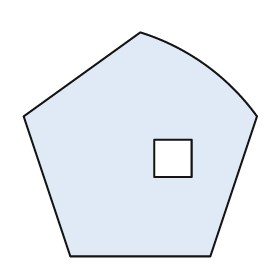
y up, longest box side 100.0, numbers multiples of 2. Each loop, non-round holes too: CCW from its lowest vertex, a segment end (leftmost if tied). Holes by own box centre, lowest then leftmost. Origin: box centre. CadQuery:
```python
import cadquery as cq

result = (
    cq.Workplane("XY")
    .moveTo(-30.0, -48.0)
    .lineTo(30.0, -48.0)
    .lineTo(50.0, 12.0)
    .threePointArc((28.0, 34.0), (0.0, 48.0))
    .lineTo(-50.0, 12.0)
    .close()
    .moveTo(6.0, -14.0)
    .lineTo(22.0, -14.0)
    .lineTo(22.0, 2.0)
    .lineTo(6.0, 2.0)
    .close()
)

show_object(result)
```